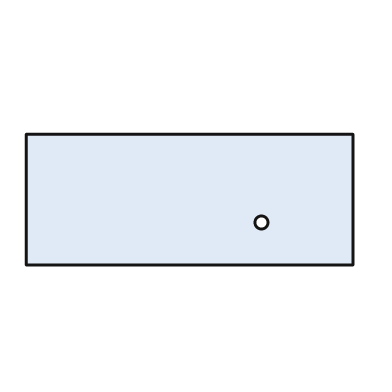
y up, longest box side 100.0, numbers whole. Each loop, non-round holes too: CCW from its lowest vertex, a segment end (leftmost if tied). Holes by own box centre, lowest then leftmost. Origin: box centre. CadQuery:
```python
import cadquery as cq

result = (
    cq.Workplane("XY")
    .moveTo(-50.0, -20.0)
    .lineTo(50.0, -20.0)
    .lineTo(50.0, 20.0)
    .lineTo(-50.0, 20.0)
    .close()
    .moveTo(22.0, -7.0)
    .circle(2.0)
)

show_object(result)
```